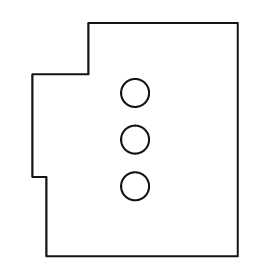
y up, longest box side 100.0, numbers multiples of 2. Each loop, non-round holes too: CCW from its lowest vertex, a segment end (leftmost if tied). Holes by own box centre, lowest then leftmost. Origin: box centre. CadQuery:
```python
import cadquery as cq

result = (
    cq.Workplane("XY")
    .moveTo(-38.0, -50.0)
    .lineTo(44.0, -50.0)
    .lineTo(44.0, 50.0)
    .lineTo(-20.0, 50.0)
    .lineTo(-20.0, 28.0)
    .lineTo(-44.0, 28.0)
    .lineTo(-44.0, -16.0)
    .lineTo(-38.0, -16.0)
    .close()
    .moveTo(0.0, -20.0)
    .circle(6.0)
    .moveTo(0.0, 0.0)
    .circle(6.0)
    .moveTo(0.0, 20.0)
    .circle(6.0)
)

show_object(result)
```